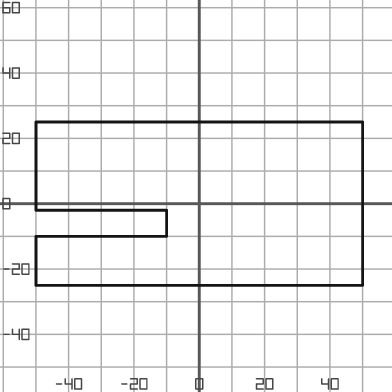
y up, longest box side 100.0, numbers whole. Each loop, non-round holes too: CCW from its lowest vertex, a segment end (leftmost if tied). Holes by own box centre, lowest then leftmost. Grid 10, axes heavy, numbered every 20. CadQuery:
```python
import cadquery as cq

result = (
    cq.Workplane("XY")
    .moveTo(-50.0, -25.0)
    .lineTo(50.0, -25.0)
    .lineTo(50.0, 25.0)
    .lineTo(-50.0, 25.0)
    .lineTo(-50.0, -2.0)
    .lineTo(-10.0, -2.0)
    .lineTo(-10.0, -10.0)
    .lineTo(-50.0, -10.0)
    .close()
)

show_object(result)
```